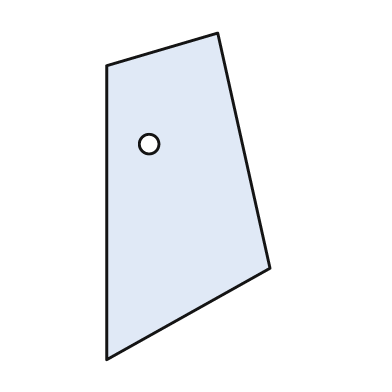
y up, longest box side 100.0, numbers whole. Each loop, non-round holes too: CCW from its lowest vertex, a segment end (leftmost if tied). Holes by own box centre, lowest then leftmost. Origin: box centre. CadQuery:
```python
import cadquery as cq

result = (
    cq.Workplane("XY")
    .moveTo(-25.0, -50.0)
    .lineTo(25.0, -22.0)
    .lineTo(9.0, 50.0)
    .lineTo(-25.0, 40.0)
    .close()
    .moveTo(-12.0, 16.0)
    .circle(3.0)
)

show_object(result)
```